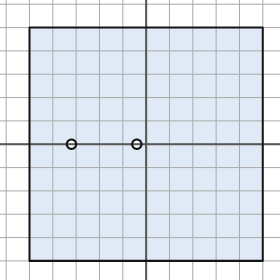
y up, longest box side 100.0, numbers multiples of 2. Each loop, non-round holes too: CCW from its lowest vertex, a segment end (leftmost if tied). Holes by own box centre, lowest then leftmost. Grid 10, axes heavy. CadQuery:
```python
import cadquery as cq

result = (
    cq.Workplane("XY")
    .moveTo(-50.0, -50.0)
    .lineTo(50.0, -50.0)
    .lineTo(50.0, 50.0)
    .lineTo(-50.0, 50.0)
    .close()
    .moveTo(-32.0, 0.0)
    .circle(2.0)
    .moveTo(-4.0, 0.0)
    .circle(2.0)
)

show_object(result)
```